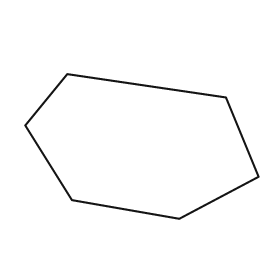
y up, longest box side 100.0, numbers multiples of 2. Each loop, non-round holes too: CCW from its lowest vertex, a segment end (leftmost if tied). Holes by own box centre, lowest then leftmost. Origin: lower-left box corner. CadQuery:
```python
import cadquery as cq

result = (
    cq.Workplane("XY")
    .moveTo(66.0, 0.0)
    .lineTo(100.0, 18.0)
    .lineTo(86.0, 52.0)
    .lineTo(18.0, 62.0)
    .lineTo(0.0, 40.0)
    .lineTo(20.0, 8.0)
    .close()
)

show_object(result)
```